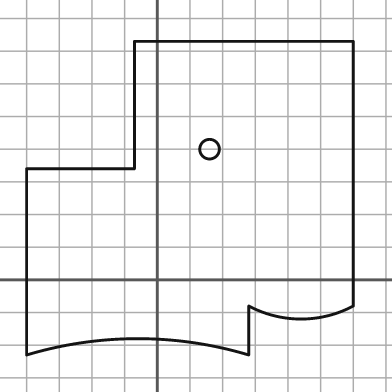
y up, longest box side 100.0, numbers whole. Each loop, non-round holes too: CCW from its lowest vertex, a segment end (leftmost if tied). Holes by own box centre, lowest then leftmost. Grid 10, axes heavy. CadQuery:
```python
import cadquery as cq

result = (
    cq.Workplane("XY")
    .moveTo(-40.0, -23.0)
    .threePointArc((-6.0, -18.0), (28.0, -23.0))
    .lineTo(28.0, -8.0)
    .threePointArc((44.0, -12.0), (60.0, -8.0))
    .lineTo(60.0, 73.0)
    .lineTo(-7.0, 73.0)
    .lineTo(-7.0, 34.0)
    .lineTo(-40.0, 34.0)
    .close()
    .moveTo(16.0, 40.0)
    .circle(3.0)
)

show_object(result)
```